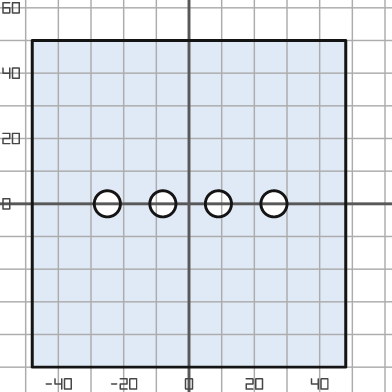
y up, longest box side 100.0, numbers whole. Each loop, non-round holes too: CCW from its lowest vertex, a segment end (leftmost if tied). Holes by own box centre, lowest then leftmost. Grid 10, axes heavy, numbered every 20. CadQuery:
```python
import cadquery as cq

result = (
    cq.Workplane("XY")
    .moveTo(-48.0, -50.0)
    .lineTo(48.0, -50.0)
    .lineTo(48.0, 50.0)
    .lineTo(-48.0, 50.0)
    .close()
    .moveTo(-25.0, 0.0)
    .circle(4.0)
    .moveTo(-8.0, 0.0)
    .circle(4.0)
    .moveTo(9.0, 0.0)
    .circle(4.0)
    .moveTo(26.0, 0.0)
    .circle(4.0)
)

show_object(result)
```